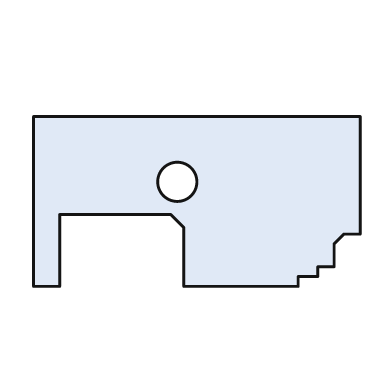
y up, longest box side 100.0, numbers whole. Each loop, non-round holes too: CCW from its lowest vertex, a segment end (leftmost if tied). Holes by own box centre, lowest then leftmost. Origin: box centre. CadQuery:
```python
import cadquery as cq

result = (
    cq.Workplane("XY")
    .moveTo(-50.0, -26.0)
    .lineTo(-42.0, -26.0)
    .lineTo(-42.0, -4.0)
    .lineTo(-8.0, -4.0)
    .lineTo(-4.0, -8.0)
    .lineTo(-4.0, -26.0)
    .lineTo(31.0, -26.0)
    .lineTo(31.0, -23.0)
    .lineTo(37.0, -23.0)
    .lineTo(37.0, -20.0)
    .lineTo(42.0, -20.0)
    .lineTo(42.0, -13.0)
    .lineTo(45.0, -10.0)
    .lineTo(50.0, -10.0)
    .lineTo(50.0, 26.0)
    .lineTo(-50.0, 26.0)
    .close()
    .moveTo(-6.0, 6.0)
    .circle(6.0)
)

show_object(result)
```